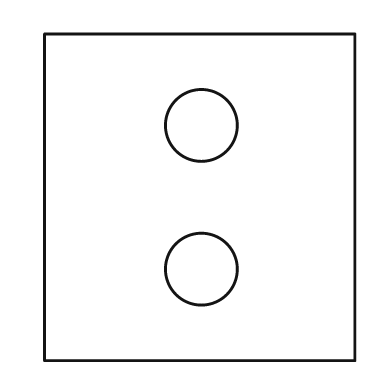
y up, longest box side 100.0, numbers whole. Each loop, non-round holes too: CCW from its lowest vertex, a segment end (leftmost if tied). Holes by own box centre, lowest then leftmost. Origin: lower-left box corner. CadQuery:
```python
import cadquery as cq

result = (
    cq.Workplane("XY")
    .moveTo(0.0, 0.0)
    .lineTo(95.0, 0.0)
    .lineTo(95.0, 100.0)
    .lineTo(0.0, 100.0)
    .close()
    .moveTo(48.0, 28.0)
    .circle(11.0)
    .moveTo(48.0, 72.0)
    .circle(11.0)
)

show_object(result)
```